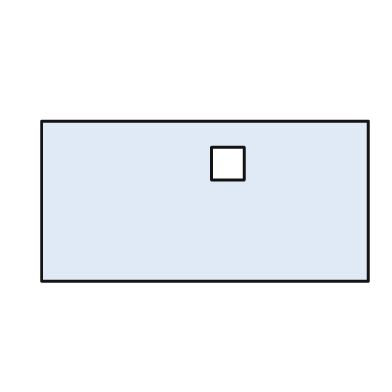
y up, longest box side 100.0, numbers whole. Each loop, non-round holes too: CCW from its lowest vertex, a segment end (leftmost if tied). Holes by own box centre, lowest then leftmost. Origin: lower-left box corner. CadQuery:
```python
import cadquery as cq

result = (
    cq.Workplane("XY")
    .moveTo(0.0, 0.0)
    .lineTo(100.0, 0.0)
    .lineTo(100.0, 49.0)
    .lineTo(0.0, 49.0)
    .close()
    .moveTo(52.0, 31.0)
    .lineTo(62.0, 31.0)
    .lineTo(62.0, 41.0)
    .lineTo(52.0, 41.0)
    .close()
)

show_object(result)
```